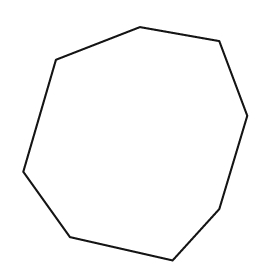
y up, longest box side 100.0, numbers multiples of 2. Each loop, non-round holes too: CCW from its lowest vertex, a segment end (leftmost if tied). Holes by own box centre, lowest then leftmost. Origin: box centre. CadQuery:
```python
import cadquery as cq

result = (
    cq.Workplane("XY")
    .moveTo(16.0, -50.0)
    .lineTo(36.0, -28.0)
    .lineTo(48.0, 12.0)
    .lineTo(36.0, 44.0)
    .lineTo(2.0, 50.0)
    .lineTo(-34.0, 36.0)
    .lineTo(-48.0, -12.0)
    .lineTo(-28.0, -40.0)
    .close()
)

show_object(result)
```